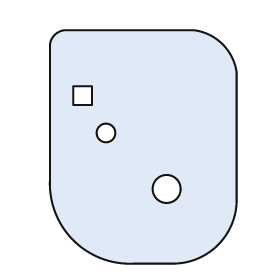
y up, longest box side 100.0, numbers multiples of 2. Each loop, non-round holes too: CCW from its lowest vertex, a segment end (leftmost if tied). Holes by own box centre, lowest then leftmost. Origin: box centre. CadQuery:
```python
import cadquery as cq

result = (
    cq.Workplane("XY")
    .moveTo(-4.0, -50.0)
    .lineTo(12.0, -50.0)
    .threePointArc((32.0, -42.0), (40.0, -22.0))
    .lineTo(40.0, 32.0)
    .threePointArc((34.0, 44.0), (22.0, 50.0))
    .lineTo(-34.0, 50.0)
    .threePointArc((-38.0, 48.0), (-40.0, 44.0))
    .lineTo(-40.0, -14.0)
    .threePointArc((-30.0, -40.0), (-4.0, -50.0))
    .close()
    .moveTo(10.0, -18.0)
    .circle(6.0)
    .moveTo(-16.0, 6.0)
    .circle(4.0)
    .moveTo(-30.0, 18.0)
    .lineTo(-22.0, 18.0)
    .lineTo(-22.0, 26.0)
    .lineTo(-30.0, 26.0)
    .close()
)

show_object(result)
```